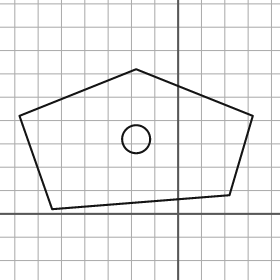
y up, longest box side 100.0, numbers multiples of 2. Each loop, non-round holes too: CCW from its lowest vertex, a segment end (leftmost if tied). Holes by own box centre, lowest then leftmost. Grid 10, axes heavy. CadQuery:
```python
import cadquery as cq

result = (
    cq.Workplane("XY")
    .moveTo(-54.0, 2.0)
    .lineTo(22.0, 8.0)
    .lineTo(32.0, 42.0)
    .lineTo(-18.0, 62.0)
    .lineTo(-68.0, 42.0)
    .close()
    .moveTo(-18.0, 32.0)
    .circle(6.0)
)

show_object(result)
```